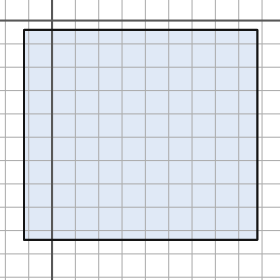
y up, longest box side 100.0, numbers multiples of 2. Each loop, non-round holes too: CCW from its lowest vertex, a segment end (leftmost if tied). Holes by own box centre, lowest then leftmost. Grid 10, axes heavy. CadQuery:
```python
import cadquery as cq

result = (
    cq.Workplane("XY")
    .moveTo(-12.0, -94.0)
    .lineTo(88.0, -94.0)
    .lineTo(88.0, -4.0)
    .lineTo(-12.0, -4.0)
    .close()
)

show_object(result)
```